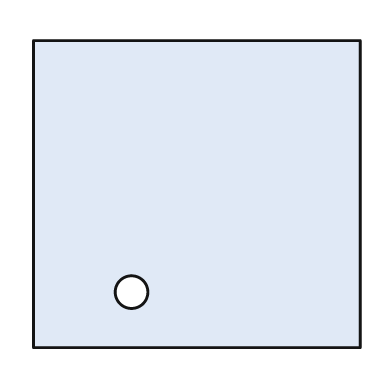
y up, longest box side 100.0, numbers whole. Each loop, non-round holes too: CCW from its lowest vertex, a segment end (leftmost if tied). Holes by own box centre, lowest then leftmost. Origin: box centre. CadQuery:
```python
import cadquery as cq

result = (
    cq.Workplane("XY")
    .moveTo(-50.0, -47.0)
    .lineTo(50.0, -47.0)
    .lineTo(50.0, 47.0)
    .lineTo(-50.0, 47.0)
    .close()
    .moveTo(-20.0, -30.0)
    .circle(5.0)
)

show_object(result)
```